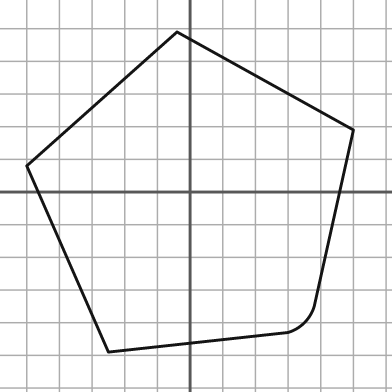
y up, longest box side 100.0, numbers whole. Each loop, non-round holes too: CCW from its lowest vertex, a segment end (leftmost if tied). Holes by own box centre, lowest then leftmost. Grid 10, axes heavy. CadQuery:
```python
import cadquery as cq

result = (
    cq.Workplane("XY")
    .moveTo(-25.0, -49.0)
    .lineTo(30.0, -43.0)
    .threePointArc((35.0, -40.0), (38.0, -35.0))
    .lineTo(50.0, 19.0)
    .lineTo(-4.0, 49.0)
    .lineTo(-50.0, 8.0)
    .close()
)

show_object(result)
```